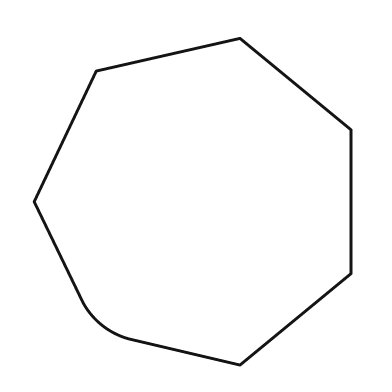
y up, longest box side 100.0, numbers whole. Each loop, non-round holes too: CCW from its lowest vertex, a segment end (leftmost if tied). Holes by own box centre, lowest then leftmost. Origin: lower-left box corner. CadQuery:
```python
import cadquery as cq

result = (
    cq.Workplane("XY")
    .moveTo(63.0, 0.0)
    .lineTo(97.0, 28.0)
    .lineTo(97.0, 72.0)
    .lineTo(63.0, 100.0)
    .lineTo(19.0, 90.0)
    .lineTo(0.0, 50.0)
    .lineTo(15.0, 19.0)
    .threePointArc((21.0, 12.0), (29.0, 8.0))
    .close()
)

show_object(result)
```